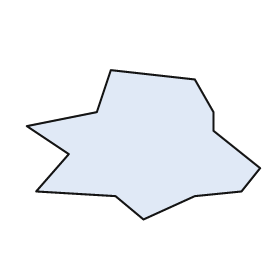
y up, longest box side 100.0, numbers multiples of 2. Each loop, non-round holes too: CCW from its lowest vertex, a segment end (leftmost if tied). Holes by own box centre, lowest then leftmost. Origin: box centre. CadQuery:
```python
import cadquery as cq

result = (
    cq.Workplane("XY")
    .moveTo(0.0, -32.0)
    .lineTo(22.0, -22.0)
    .lineTo(42.0, -20.0)
    .lineTo(50.0, -10.0)
    .lineTo(30.0, 6.0)
    .lineTo(30.0, 14.0)
    .lineTo(22.0, 28.0)
    .lineTo(-14.0, 32.0)
    .lineTo(-20.0, 14.0)
    .lineTo(-50.0, 8.0)
    .lineTo(-32.0, -4.0)
    .lineTo(-46.0, -20.0)
    .lineTo(-12.0, -22.0)
    .close()
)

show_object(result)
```